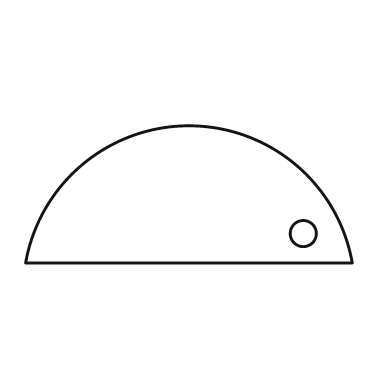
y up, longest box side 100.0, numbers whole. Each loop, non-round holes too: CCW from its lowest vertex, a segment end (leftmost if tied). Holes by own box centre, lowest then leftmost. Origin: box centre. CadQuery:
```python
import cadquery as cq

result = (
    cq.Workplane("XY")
    .moveTo(-50.0, -21.0)
    .lineTo(50.0, -21.0)
    .threePointArc((0.0, 21.0), (-50.0, -21.0))
    .close()
    .moveTo(35.0, -12.0)
    .circle(4.0)
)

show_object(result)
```